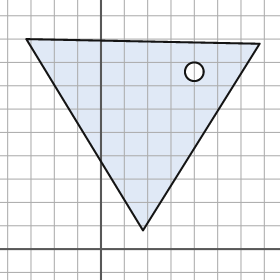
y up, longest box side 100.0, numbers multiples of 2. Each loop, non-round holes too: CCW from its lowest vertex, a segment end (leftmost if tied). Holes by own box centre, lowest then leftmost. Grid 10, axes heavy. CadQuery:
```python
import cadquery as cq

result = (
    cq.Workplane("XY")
    .moveTo(18.0, 8.0)
    .lineTo(68.0, 88.0)
    .lineTo(-32.0, 90.0)
    .close()
    .moveTo(40.0, 76.0)
    .circle(4.0)
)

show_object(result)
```